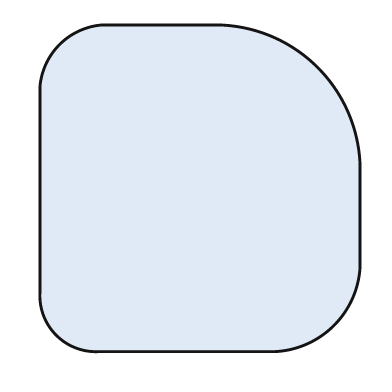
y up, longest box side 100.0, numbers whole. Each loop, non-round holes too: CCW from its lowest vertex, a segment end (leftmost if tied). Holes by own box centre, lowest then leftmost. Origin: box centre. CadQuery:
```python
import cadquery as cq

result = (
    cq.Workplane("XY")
    .moveTo(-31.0, -50.0)
    .lineTo(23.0, -50.0)
    .threePointArc((41.0, -42.0), (49.0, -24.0))
    .lineTo(49.0, 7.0)
    .threePointArc((36.0, 37.0), (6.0, 50.0))
    .lineTo(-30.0, 50.0)
    .threePointArc((-43.0, 44.0), (-49.0, 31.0))
    .lineTo(-49.0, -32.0)
    .threePointArc((-44.0, -45.0), (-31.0, -50.0))
    .close()
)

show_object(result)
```